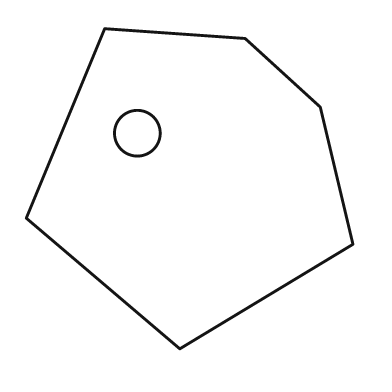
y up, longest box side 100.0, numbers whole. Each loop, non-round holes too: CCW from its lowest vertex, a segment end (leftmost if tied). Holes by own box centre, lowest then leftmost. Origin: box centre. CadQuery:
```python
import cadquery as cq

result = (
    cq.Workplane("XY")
    .moveTo(-3.0, -49.0)
    .lineTo(50.0, -17.0)
    .lineTo(40.0, 25.0)
    .lineTo(17.0, 46.0)
    .lineTo(-26.0, 49.0)
    .lineTo(-50.0, -9.0)
    .close()
    .moveTo(-16.0, 17.0)
    .circle(7.0)
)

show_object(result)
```